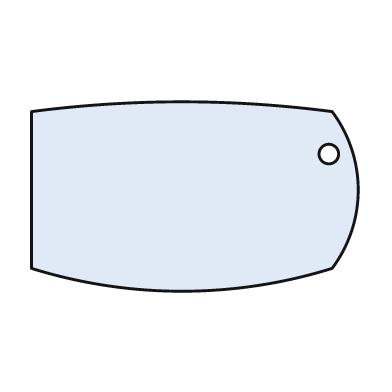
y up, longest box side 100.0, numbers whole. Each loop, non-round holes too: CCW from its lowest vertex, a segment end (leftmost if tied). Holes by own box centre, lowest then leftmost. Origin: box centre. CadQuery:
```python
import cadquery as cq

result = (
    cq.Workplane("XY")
    .moveTo(-50.0, -22.0)
    .threePointArc((-4.0, -29.0), (42.0, -22.0))
    .threePointArc((50.0, 2.0), (42.0, 26.0))
    .threePointArc((-4.0, 29.0), (-50.0, 26.0))
    .close()
    .moveTo(41.0, 13.0)
    .circle(3.0)
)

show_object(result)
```